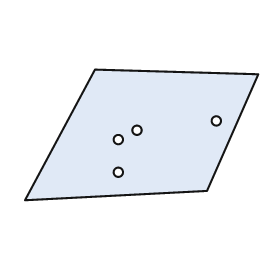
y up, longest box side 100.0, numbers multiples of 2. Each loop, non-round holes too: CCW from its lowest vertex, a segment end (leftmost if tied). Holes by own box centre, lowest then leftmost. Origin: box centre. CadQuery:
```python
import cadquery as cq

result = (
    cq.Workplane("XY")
    .moveTo(-50.0, -28.0)
    .lineTo(28.0, -24.0)
    .lineTo(50.0, 26.0)
    .lineTo(-20.0, 28.0)
    .close()
    .moveTo(-10.0, -16.0)
    .circle(2.0)
    .moveTo(-10.0, -2.0)
    .circle(2.0)
    .moveTo(-2.0, 2.0)
    .circle(2.0)
    .moveTo(32.0, 6.0)
    .circle(2.0)
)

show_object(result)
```